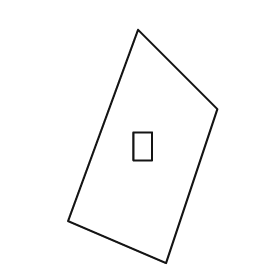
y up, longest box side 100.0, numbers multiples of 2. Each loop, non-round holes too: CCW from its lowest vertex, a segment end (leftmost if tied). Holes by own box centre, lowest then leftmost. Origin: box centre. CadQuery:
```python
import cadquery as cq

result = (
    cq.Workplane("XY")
    .moveTo(10.0, -50.0)
    .lineTo(32.0, 16.0)
    .lineTo(-2.0, 50.0)
    .lineTo(-32.0, -32.0)
    .close()
    .moveTo(-4.0, -6.0)
    .lineTo(4.0, -6.0)
    .lineTo(4.0, 6.0)
    .lineTo(-4.0, 6.0)
    .close()
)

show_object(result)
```